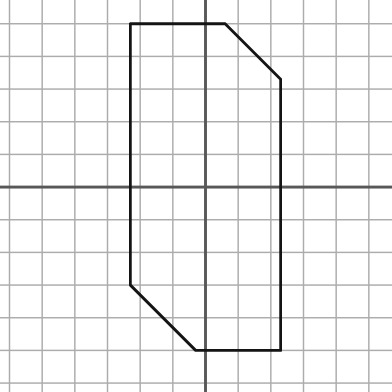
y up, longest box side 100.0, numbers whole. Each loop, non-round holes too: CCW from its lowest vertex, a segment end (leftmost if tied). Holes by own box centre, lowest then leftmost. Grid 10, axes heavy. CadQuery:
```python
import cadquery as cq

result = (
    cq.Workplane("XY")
    .moveTo(-3.0, -50.0)
    .lineTo(23.0, -50.0)
    .lineTo(23.0, 33.0)
    .lineTo(6.0, 50.0)
    .lineTo(-23.0, 50.0)
    .lineTo(-23.0, -30.0)
    .close()
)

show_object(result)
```